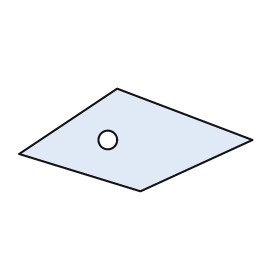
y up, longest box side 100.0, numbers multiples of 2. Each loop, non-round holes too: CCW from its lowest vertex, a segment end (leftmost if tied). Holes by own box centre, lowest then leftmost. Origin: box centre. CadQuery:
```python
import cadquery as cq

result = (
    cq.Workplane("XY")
    .moveTo(2.0, -22.0)
    .lineTo(50.0, 0.0)
    .lineTo(-8.0, 22.0)
    .lineTo(-50.0, -6.0)
    .close()
    .moveTo(-12.0, 0.0)
    .circle(4.0)
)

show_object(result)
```